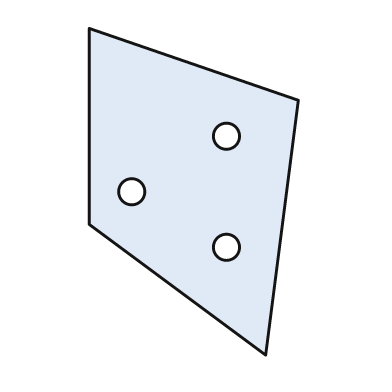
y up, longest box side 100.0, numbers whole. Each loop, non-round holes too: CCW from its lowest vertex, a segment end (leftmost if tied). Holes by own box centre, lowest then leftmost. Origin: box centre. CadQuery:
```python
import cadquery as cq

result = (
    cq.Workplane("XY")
    .moveTo(22.0, -50.0)
    .lineTo(32.0, 28.0)
    .lineTo(-32.0, 50.0)
    .lineTo(-32.0, -10.0)
    .close()
    .moveTo(10.0, -17.0)
    .circle(4.0)
    .moveTo(-19.0, 0.0)
    .circle(4.0)
    .moveTo(10.0, 17.0)
    .circle(4.0)
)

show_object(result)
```